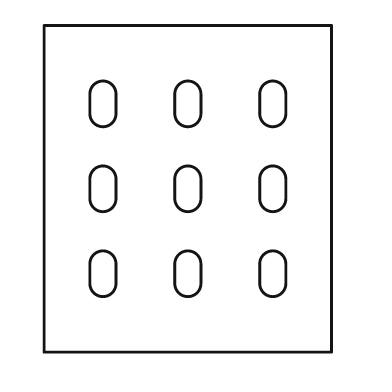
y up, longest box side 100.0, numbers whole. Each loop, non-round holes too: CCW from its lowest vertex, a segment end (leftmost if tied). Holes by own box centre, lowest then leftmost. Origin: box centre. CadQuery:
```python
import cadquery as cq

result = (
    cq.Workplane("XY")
    .moveTo(-44.0, -50.0)
    .lineTo(44.0, -50.0)
    .lineTo(44.0, 50.0)
    .lineTo(-44.0, 50.0)
    .close()
    .moveTo(-30.0, -29.0)
    .threePointArc((-26.0, -33.0), (-22.0, -29.0))
    .lineTo(-22.0, -23.0)
    .threePointArc((-26.0, -19.0), (-30.0, -23.0))
    .close()
    .moveTo(-4.0, -29.0)
    .threePointArc((0.0, -33.0), (4.0, -29.0))
    .lineTo(4.0, -23.0)
    .threePointArc((0.0, -19.0), (-4.0, -23.0))
    .close()
    .moveTo(22.0, -29.0)
    .threePointArc((26.0, -33.0), (30.0, -29.0))
    .lineTo(30.0, -23.0)
    .threePointArc((26.0, -19.0), (22.0, -23.0))
    .close()
    .moveTo(-30.0, -3.0)
    .threePointArc((-26.0, -7.0), (-22.0, -3.0))
    .lineTo(-22.0, 3.0)
    .threePointArc((-26.0, 7.0), (-30.0, 3.0))
    .close()
    .moveTo(-4.0, -3.0)
    .threePointArc((0.0, -7.0), (4.0, -3.0))
    .lineTo(4.0, 3.0)
    .threePointArc((0.0, 7.0), (-4.0, 3.0))
    .close()
    .moveTo(22.0, -3.0)
    .threePointArc((26.0, -7.0), (30.0, -3.0))
    .lineTo(30.0, 3.0)
    .threePointArc((26.0, 7.0), (22.0, 3.0))
    .close()
    .moveTo(-30.0, 23.0)
    .threePointArc((-26.0, 19.0), (-22.0, 23.0))
    .lineTo(-22.0, 29.0)
    .threePointArc((-26.0, 33.0), (-30.0, 29.0))
    .close()
    .moveTo(-4.0, 23.0)
    .threePointArc((0.0, 19.0), (4.0, 23.0))
    .lineTo(4.0, 29.0)
    .threePointArc((0.0, 33.0), (-4.0, 29.0))
    .close()
    .moveTo(22.0, 23.0)
    .threePointArc((26.0, 19.0), (30.0, 23.0))
    .lineTo(30.0, 29.0)
    .threePointArc((26.0, 33.0), (22.0, 29.0))
    .close()
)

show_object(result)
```